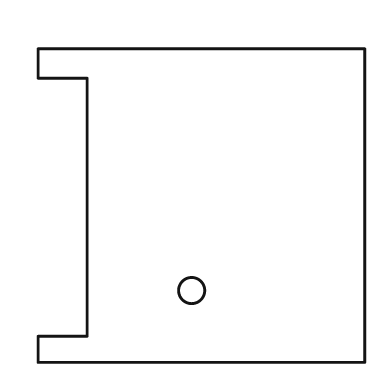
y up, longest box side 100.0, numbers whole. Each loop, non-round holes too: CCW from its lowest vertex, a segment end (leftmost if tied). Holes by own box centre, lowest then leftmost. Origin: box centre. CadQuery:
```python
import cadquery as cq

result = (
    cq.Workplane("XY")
    .moveTo(-50.0, -48.0)
    .lineTo(50.0, -48.0)
    .lineTo(50.0, 48.0)
    .lineTo(-50.0, 48.0)
    .lineTo(-50.0, 39.0)
    .lineTo(-35.0, 39.0)
    .lineTo(-35.0, -40.0)
    .lineTo(-50.0, -40.0)
    .close()
    .moveTo(-3.0, -26.0)
    .circle(4.0)
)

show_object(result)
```